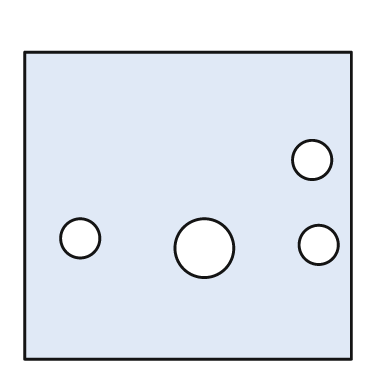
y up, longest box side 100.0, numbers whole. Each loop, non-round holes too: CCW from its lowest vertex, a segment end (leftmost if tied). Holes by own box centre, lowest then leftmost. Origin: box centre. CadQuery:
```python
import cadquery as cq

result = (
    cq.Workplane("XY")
    .moveTo(-50.0, -47.0)
    .lineTo(50.0, -47.0)
    .lineTo(50.0, 47.0)
    .lineTo(-50.0, 47.0)
    .close()
    .moveTo(5.0, -13.0)
    .circle(9.0)
    .moveTo(40.0, -12.0)
    .circle(6.0)
    .moveTo(-33.0, -10.0)
    .circle(6.0)
    .moveTo(38.0, 14.0)
    .circle(6.0)
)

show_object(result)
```